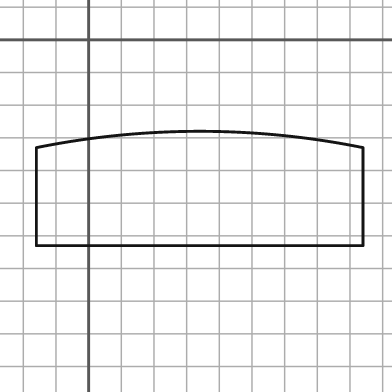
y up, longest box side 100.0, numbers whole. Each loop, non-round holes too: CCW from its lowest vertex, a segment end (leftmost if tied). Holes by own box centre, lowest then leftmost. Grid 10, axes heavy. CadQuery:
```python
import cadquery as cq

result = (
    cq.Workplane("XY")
    .moveTo(-16.0, -63.0)
    .lineTo(84.0, -63.0)
    .lineTo(84.0, -33.0)
    .threePointArc((34.0, -28.0), (-16.0, -33.0))
    .close()
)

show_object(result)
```